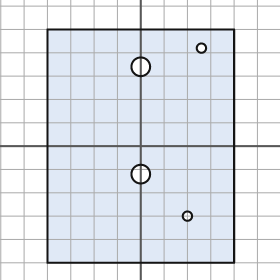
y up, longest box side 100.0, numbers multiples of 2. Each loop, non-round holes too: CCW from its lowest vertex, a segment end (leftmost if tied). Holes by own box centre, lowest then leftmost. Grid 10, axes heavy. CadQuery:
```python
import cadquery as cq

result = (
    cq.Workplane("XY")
    .moveTo(-40.0, -50.0)
    .lineTo(40.0, -50.0)
    .lineTo(40.0, 50.0)
    .lineTo(-40.0, 50.0)
    .close()
    .moveTo(20.0, -30.0)
    .circle(2.0)
    .moveTo(0.0, -12.0)
    .circle(4.0)
    .moveTo(0.0, 34.0)
    .circle(4.0)
    .moveTo(26.0, 42.0)
    .circle(2.0)
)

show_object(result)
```